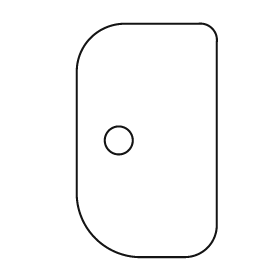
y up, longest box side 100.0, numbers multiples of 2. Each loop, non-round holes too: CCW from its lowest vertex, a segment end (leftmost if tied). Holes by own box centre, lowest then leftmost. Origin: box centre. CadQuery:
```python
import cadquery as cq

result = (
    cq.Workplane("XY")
    .moveTo(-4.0, -50.0)
    .lineTo(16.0, -50.0)
    .threePointArc((26.0, -46.0), (30.0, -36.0))
    .lineTo(30.0, 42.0)
    .threePointArc((28.0, 48.0), (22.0, 50.0))
    .lineTo(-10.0, 50.0)
    .threePointArc((-24.0, 44.0), (-30.0, 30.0))
    .lineTo(-30.0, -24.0)
    .threePointArc((-22.0, -42.0), (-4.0, -50.0))
    .close()
    .moveTo(-12.0, 0.0)
    .circle(6.0)
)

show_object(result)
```